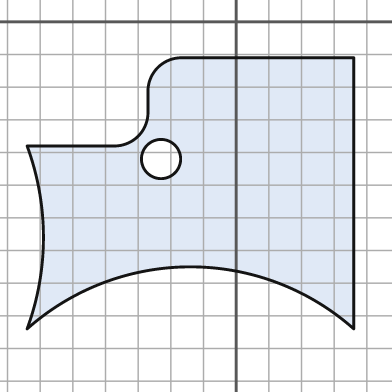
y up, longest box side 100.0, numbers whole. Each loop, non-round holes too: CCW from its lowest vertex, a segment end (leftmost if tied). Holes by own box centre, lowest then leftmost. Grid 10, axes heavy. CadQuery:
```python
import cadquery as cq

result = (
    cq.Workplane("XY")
    .moveTo(-64.0, -94.0)
    .threePointArc((-14.0, -75.0), (36.0, -94.0))
    .lineTo(36.0, -11.0)
    .lineTo(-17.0, -11.0)
    .threePointArc((-24.0, -14.0), (-27.0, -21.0))
    .lineTo(-27.0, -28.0)
    .threePointArc((-30.0, -35.0), (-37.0, -38.0))
    .lineTo(-64.0, -38.0)
    .threePointArc((-59.0, -66.0), (-64.0, -94.0))
    .close()
    .moveTo(-23.0, -42.0)
    .circle(6.0)
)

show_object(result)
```